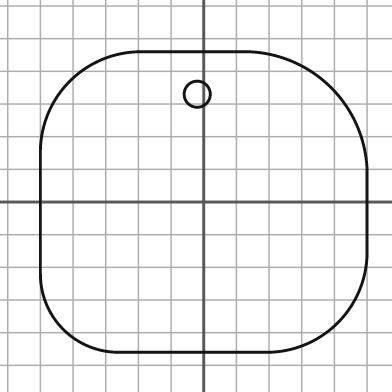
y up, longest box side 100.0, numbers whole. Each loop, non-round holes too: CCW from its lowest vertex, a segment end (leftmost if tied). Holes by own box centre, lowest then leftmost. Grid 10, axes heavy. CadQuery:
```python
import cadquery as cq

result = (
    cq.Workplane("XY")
    .moveTo(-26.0, -46.0)
    .lineTo(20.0, -46.0)
    .threePointArc((41.0, -37.0), (50.0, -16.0))
    .lineTo(50.0, 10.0)
    .threePointArc((39.0, 35.0), (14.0, 46.0))
    .lineTo(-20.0, 46.0)
    .threePointArc((-41.0, 37.0), (-50.0, 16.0))
    .lineTo(-50.0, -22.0)
    .threePointArc((-43.0, -39.0), (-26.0, -46.0))
    .close()
    .moveTo(-2.0, 33.0)
    .circle(4.0)
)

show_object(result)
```